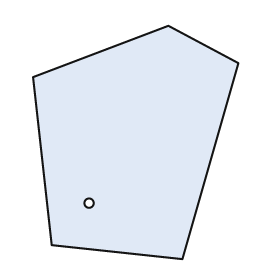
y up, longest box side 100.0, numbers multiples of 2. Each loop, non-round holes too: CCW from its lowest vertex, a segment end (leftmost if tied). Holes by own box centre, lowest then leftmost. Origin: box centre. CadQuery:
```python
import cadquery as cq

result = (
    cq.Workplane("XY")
    .moveTo(20.0, -50.0)
    .lineTo(44.0, 34.0)
    .lineTo(14.0, 50.0)
    .lineTo(-44.0, 28.0)
    .lineTo(-36.0, -44.0)
    .close()
    .moveTo(-20.0, -26.0)
    .circle(2.0)
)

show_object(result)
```